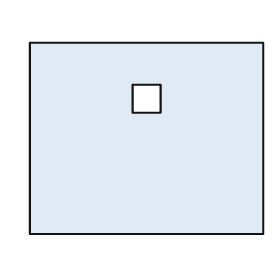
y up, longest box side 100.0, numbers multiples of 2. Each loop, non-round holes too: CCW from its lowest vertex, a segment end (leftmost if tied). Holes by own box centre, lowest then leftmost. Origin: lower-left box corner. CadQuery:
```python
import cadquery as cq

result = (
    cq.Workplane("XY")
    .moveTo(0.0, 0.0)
    .lineTo(100.0, 0.0)
    .lineTo(100.0, 82.0)
    .lineTo(0.0, 82.0)
    .close()
    .moveTo(44.0, 52.0)
    .lineTo(56.0, 52.0)
    .lineTo(56.0, 64.0)
    .lineTo(44.0, 64.0)
    .close()
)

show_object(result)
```